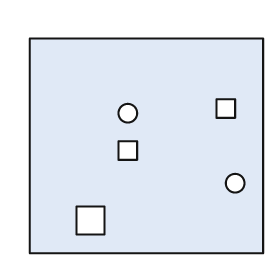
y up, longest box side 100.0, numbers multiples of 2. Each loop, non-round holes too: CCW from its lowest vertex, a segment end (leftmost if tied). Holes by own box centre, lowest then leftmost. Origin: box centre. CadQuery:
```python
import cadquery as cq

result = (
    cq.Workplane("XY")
    .moveTo(-50.0, -46.0)
    .lineTo(50.0, -46.0)
    .lineTo(50.0, 46.0)
    .lineTo(-50.0, 46.0)
    .close()
    .moveTo(-30.0, -38.0)
    .lineTo(-18.0, -38.0)
    .lineTo(-18.0, -26.0)
    .lineTo(-30.0, -26.0)
    .close()
    .moveTo(38.0, -16.0)
    .circle(4.0)
    .moveTo(-12.0, -6.0)
    .lineTo(-4.0, -6.0)
    .lineTo(-4.0, 2.0)
    .lineTo(-12.0, 2.0)
    .close()
    .moveTo(-8.0, 14.0)
    .circle(4.0)
    .moveTo(30.0, 12.0)
    .lineTo(38.0, 12.0)
    .lineTo(38.0, 20.0)
    .lineTo(30.0, 20.0)
    .close()
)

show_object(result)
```